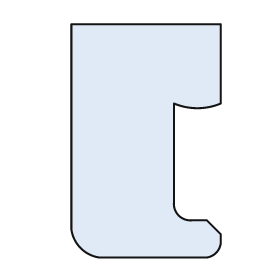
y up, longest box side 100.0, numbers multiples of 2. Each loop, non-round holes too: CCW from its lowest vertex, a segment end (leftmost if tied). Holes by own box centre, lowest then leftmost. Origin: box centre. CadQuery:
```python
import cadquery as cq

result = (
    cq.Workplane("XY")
    .moveTo(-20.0, -50.0)
    .lineTo(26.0, -50.0)
    .threePointArc((30.0, -48.0), (32.0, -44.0))
    .lineTo(32.0, -40.0)
    .lineTo(26.0, -34.0)
    .lineTo(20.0, -34.0)
    .threePointArc((14.0, -32.0), (12.0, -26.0))
    .lineTo(12.0, 16.0)
    .threePointArc((22.0, 14.0), (32.0, 16.0))
    .lineTo(32.0, 50.0)
    .lineTo(-32.0, 50.0)
    .lineTo(-32.0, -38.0)
    .threePointArc((-28.0, -46.0), (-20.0, -50.0))
    .close()
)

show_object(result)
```